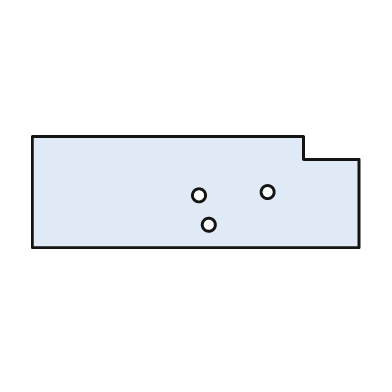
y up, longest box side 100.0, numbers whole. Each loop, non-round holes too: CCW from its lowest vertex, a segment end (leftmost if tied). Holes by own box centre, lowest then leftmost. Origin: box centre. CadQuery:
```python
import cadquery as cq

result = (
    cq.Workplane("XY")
    .moveTo(-50.0, -17.0)
    .lineTo(50.0, -17.0)
    .lineTo(50.0, 10.0)
    .lineTo(33.0, 10.0)
    .lineTo(33.0, 17.0)
    .lineTo(-50.0, 17.0)
    .close()
    .moveTo(4.0, -10.0)
    .circle(2.0)
    .moveTo(1.0, -1.0)
    .circle(2.0)
    .moveTo(22.0, 0.0)
    .circle(2.0)
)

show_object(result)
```